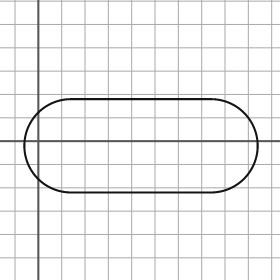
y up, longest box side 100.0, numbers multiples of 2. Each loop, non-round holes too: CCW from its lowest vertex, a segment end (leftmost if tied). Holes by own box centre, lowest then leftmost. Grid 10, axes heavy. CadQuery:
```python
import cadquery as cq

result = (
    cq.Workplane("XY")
    .moveTo(14.0, -22.0)
    .lineTo(74.0, -22.0)
    .threePointArc((94.0, -2.0), (74.0, 18.0))
    .lineTo(14.0, 18.0)
    .threePointArc((-6.0, -2.0), (14.0, -22.0))
    .close()
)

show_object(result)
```